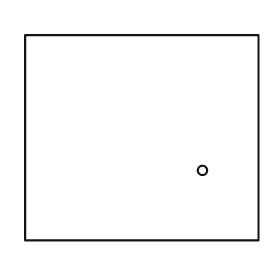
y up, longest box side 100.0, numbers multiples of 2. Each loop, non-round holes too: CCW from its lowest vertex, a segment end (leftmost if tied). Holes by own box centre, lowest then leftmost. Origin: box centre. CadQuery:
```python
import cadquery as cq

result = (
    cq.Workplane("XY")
    .moveTo(-50.0, -44.0)
    .lineTo(50.0, -44.0)
    .lineTo(50.0, 44.0)
    .lineTo(-50.0, 44.0)
    .close()
    .moveTo(26.0, -14.0)
    .circle(2.0)
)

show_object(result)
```